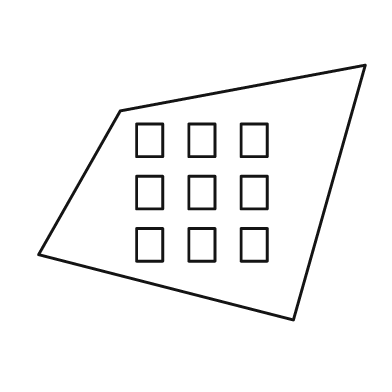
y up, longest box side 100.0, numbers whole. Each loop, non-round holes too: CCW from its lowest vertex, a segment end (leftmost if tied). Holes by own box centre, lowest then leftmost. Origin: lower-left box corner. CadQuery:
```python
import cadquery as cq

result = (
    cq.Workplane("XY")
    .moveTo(78.0, 0.0)
    .lineTo(100.0, 78.0)
    .lineTo(25.0, 64.0)
    .lineTo(0.0, 20.0)
    .close()
    .moveTo(30.0, 18.0)
    .lineTo(38.0, 18.0)
    .lineTo(38.0, 28.0)
    .lineTo(30.0, 28.0)
    .close()
    .moveTo(46.0, 18.0)
    .lineTo(54.0, 18.0)
    .lineTo(54.0, 28.0)
    .lineTo(46.0, 28.0)
    .close()
    .moveTo(62.0, 18.0)
    .lineTo(70.0, 18.0)
    .lineTo(70.0, 28.0)
    .lineTo(62.0, 28.0)
    .close()
    .moveTo(30.0, 34.0)
    .lineTo(38.0, 34.0)
    .lineTo(38.0, 44.0)
    .lineTo(30.0, 44.0)
    .close()
    .moveTo(46.0, 34.0)
    .lineTo(54.0, 34.0)
    .lineTo(54.0, 44.0)
    .lineTo(46.0, 44.0)
    .close()
    .moveTo(62.0, 34.0)
    .lineTo(70.0, 34.0)
    .lineTo(70.0, 44.0)
    .lineTo(62.0, 44.0)
    .close()
    .moveTo(30.0, 50.0)
    .lineTo(38.0, 50.0)
    .lineTo(38.0, 60.0)
    .lineTo(30.0, 60.0)
    .close()
    .moveTo(46.0, 50.0)
    .lineTo(54.0, 50.0)
    .lineTo(54.0, 60.0)
    .lineTo(46.0, 60.0)
    .close()
    .moveTo(62.0, 50.0)
    .lineTo(70.0, 50.0)
    .lineTo(70.0, 60.0)
    .lineTo(62.0, 60.0)
    .close()
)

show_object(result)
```